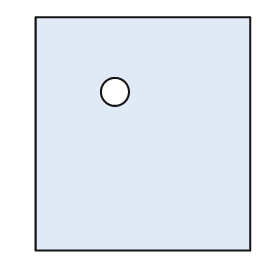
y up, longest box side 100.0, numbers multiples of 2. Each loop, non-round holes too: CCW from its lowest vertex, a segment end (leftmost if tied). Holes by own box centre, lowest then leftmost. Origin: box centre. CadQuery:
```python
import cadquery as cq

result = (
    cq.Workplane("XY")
    .moveTo(-46.0, -50.0)
    .lineTo(46.0, -50.0)
    .lineTo(46.0, 50.0)
    .lineTo(-46.0, 50.0)
    .close()
    .moveTo(-12.0, 18.0)
    .circle(6.0)
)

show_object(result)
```